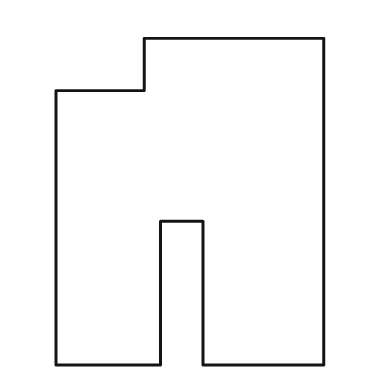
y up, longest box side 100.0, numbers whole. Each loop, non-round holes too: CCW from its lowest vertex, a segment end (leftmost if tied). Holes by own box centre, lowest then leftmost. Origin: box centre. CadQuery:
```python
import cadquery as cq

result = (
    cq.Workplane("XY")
    .moveTo(-41.0, -50.0)
    .lineTo(-9.0, -50.0)
    .lineTo(-9.0, -6.0)
    .lineTo(4.0, -6.0)
    .lineTo(4.0, -50.0)
    .lineTo(41.0, -50.0)
    .lineTo(41.0, 50.0)
    .lineTo(-14.0, 50.0)
    .lineTo(-14.0, 34.0)
    .lineTo(-41.0, 34.0)
    .close()
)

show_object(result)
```